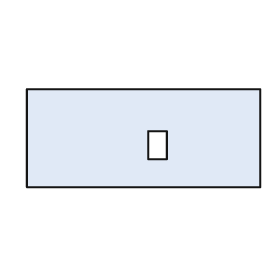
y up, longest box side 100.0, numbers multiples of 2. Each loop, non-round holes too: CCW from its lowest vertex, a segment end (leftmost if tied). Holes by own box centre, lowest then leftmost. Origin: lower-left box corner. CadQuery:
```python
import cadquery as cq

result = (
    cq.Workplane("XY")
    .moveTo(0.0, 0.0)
    .lineTo(100.0, 0.0)
    .lineTo(100.0, 42.0)
    .lineTo(0.0, 42.0)
    .close()
    .moveTo(52.0, 12.0)
    .lineTo(60.0, 12.0)
    .lineTo(60.0, 24.0)
    .lineTo(52.0, 24.0)
    .close()
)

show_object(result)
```